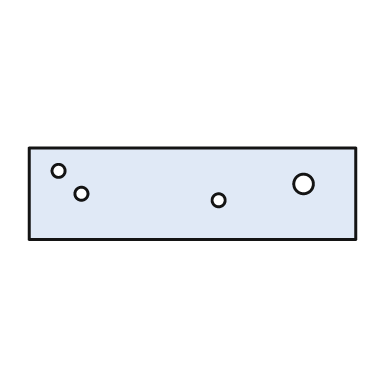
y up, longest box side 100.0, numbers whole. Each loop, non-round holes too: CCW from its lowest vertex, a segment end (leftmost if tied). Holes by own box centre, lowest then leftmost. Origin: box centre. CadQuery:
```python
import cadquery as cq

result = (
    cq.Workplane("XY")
    .moveTo(-50.0, -14.0)
    .lineTo(50.0, -14.0)
    .lineTo(50.0, 14.0)
    .lineTo(-50.0, 14.0)
    .close()
    .moveTo(8.0, -2.0)
    .circle(2.0)
    .moveTo(-34.0, 0.0)
    .circle(2.0)
    .moveTo(34.0, 3.0)
    .circle(3.0)
    .moveTo(-41.0, 7.0)
    .circle(2.0)
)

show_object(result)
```